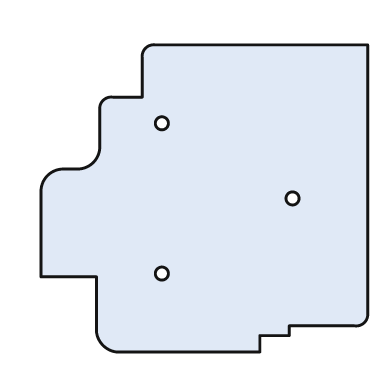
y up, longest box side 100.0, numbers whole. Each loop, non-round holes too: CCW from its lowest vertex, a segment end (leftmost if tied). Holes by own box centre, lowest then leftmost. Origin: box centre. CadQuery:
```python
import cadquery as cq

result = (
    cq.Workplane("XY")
    .moveTo(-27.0, -47.0)
    .lineTo(17.0, -47.0)
    .lineTo(17.0, -42.0)
    .lineTo(26.0, -42.0)
    .lineTo(26.0, -39.0)
    .lineTo(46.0, -39.0)
    .threePointArc((49.0, -38.0), (50.0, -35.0))
    .lineTo(50.0, 47.0)
    .lineTo(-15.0, 47.0)
    .threePointArc((-18.0, 46.0), (-19.0, 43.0))
    .lineTo(-19.0, 31.0)
    .lineTo(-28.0, 31.0)
    .threePointArc((-31.0, 30.0), (-32.0, 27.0))
    .lineTo(-32.0, 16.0)
    .threePointArc((-34.0, 11.0), (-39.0, 9.0))
    .lineTo(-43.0, 9.0)
    .threePointArc((-48.0, 7.0), (-50.0, 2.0))
    .lineTo(-50.0, -24.0)
    .lineTo(-33.0, -24.0)
    .lineTo(-33.0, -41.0)
    .threePointArc((-31.0, -45.0), (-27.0, -47.0))
    .close()
    .moveTo(-13.0, -23.0)
    .circle(2.0)
    .moveTo(27.0, 0.0)
    .circle(2.0)
    .moveTo(-13.0, 23.0)
    .circle(2.0)
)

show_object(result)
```